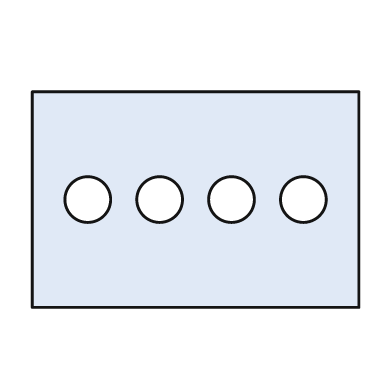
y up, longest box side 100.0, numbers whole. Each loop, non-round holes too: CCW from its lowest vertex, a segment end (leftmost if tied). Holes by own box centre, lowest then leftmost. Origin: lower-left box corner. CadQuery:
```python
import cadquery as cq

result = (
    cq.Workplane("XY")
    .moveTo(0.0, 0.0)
    .lineTo(100.0, 0.0)
    .lineTo(100.0, 66.0)
    .lineTo(0.0, 66.0)
    .close()
    .moveTo(17.0, 33.0)
    .circle(7.0)
    .moveTo(39.0, 33.0)
    .circle(7.0)
    .moveTo(61.0, 33.0)
    .circle(7.0)
    .moveTo(83.0, 33.0)
    .circle(7.0)
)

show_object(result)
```